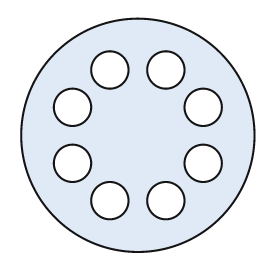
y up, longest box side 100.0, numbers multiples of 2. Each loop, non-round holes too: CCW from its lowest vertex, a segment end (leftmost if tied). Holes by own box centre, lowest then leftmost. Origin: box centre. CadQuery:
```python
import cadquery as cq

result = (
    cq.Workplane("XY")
    .moveTo(0.0, 0.0)
    .circle(50.0)
    .moveTo(-12.0, -28.0)
    .circle(8.0)
    .moveTo(12.0, -28.0)
    .circle(8.0)
    .moveTo(-28.0, -12.0)
    .circle(8.0)
    .moveTo(28.0, -12.0)
    .circle(8.0)
    .moveTo(-28.0, 12.0)
    .circle(8.0)
    .moveTo(28.0, 12.0)
    .circle(8.0)
    .moveTo(-12.0, 28.0)
    .circle(8.0)
    .moveTo(12.0, 28.0)
    .circle(8.0)
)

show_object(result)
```